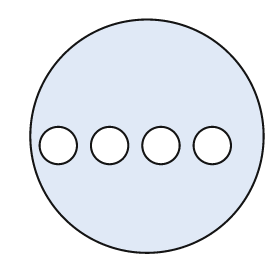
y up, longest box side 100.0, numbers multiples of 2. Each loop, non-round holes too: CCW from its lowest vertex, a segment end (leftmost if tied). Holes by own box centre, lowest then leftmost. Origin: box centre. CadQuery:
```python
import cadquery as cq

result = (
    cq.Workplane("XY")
    .moveTo(0.0, 0.0)
    .circle(50.0)
    .moveTo(-38.0, -4.0)
    .circle(8.0)
    .moveTo(-16.0, -4.0)
    .circle(8.0)
    .moveTo(6.0, -4.0)
    .circle(8.0)
    .moveTo(28.0, -4.0)
    .circle(8.0)
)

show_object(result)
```